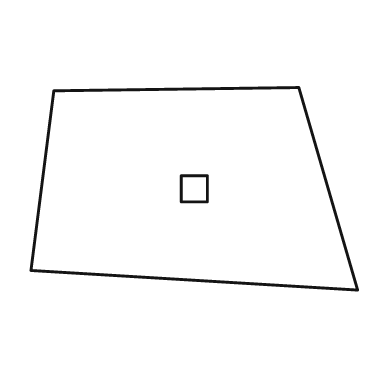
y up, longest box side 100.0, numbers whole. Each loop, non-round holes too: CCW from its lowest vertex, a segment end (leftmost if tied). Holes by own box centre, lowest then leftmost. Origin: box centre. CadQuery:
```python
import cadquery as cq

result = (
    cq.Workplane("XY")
    .moveTo(50.0, -31.0)
    .lineTo(32.0, 31.0)
    .lineTo(-43.0, 30.0)
    .lineTo(-50.0, -25.0)
    .close()
    .moveTo(-4.0, -4.0)
    .lineTo(4.0, -4.0)
    .lineTo(4.0, 4.0)
    .lineTo(-4.0, 4.0)
    .close()
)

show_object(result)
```